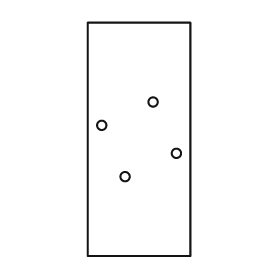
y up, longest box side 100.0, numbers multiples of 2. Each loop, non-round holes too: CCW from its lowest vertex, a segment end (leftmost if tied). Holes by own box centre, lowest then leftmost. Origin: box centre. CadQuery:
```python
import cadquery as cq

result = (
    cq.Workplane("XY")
    .moveTo(-22.0, -50.0)
    .lineTo(22.0, -50.0)
    .lineTo(22.0, 50.0)
    .lineTo(-22.0, 50.0)
    .close()
    .moveTo(-6.0, -16.0)
    .circle(2.0)
    .moveTo(16.0, -6.0)
    .circle(2.0)
    .moveTo(-16.0, 6.0)
    .circle(2.0)
    .moveTo(6.0, 16.0)
    .circle(2.0)
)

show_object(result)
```